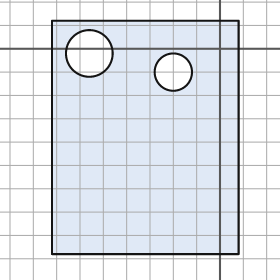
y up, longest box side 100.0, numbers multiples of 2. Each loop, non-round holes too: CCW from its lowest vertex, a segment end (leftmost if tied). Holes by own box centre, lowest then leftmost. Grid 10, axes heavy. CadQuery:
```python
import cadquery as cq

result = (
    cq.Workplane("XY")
    .moveTo(-72.0, -88.0)
    .lineTo(8.0, -88.0)
    .lineTo(8.0, 12.0)
    .lineTo(-72.0, 12.0)
    .close()
    .moveTo(-20.0, -10.0)
    .circle(8.0)
    .moveTo(-56.0, -2.0)
    .circle(10.0)
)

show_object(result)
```